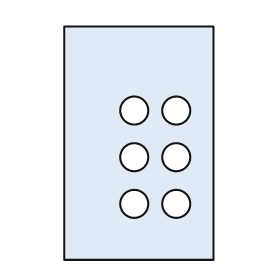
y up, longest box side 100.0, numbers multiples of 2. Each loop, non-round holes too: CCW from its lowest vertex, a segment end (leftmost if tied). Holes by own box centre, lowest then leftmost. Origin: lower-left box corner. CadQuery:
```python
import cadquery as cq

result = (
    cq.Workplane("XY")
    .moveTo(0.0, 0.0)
    .lineTo(64.0, 0.0)
    .lineTo(64.0, 100.0)
    .lineTo(0.0, 100.0)
    .close()
    .moveTo(30.0, 24.0)
    .circle(6.0)
    .moveTo(48.0, 24.0)
    .circle(6.0)
    .moveTo(30.0, 44.0)
    .circle(6.0)
    .moveTo(48.0, 44.0)
    .circle(6.0)
    .moveTo(30.0, 64.0)
    .circle(6.0)
    .moveTo(48.0, 64.0)
    .circle(6.0)
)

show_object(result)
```